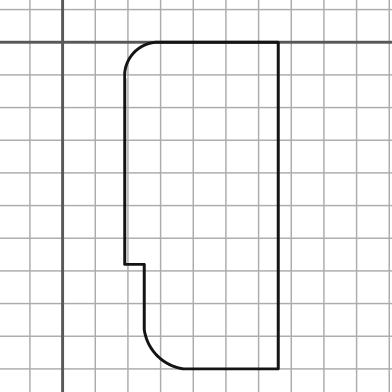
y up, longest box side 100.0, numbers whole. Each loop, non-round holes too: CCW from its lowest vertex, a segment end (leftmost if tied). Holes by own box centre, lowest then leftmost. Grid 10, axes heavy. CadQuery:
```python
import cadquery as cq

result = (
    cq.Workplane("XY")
    .moveTo(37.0, -100.0)
    .lineTo(66.0, -100.0)
    .lineTo(66.0, 0.0)
    .lineTo(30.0, 0.0)
    .threePointArc((22.0, -3.0), (19.0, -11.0))
    .lineTo(19.0, -68.0)
    .lineTo(25.0, -68.0)
    .lineTo(25.0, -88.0)
    .threePointArc((29.0, -96.0), (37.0, -100.0))
    .close()
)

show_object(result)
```